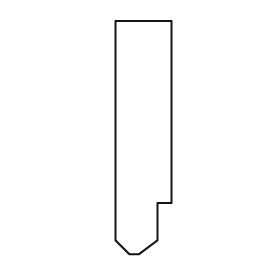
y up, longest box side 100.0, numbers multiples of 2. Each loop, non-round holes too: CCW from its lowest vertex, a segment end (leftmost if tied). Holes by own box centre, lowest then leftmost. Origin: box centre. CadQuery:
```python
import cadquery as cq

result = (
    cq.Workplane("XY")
    .moveTo(-6.0, -50.0)
    .lineTo(-2.0, -50.0)
    .lineTo(6.0, -44.0)
    .lineTo(6.0, -28.0)
    .lineTo(12.0, -28.0)
    .lineTo(12.0, 50.0)
    .lineTo(-12.0, 50.0)
    .lineTo(-12.0, -44.0)
    .close()
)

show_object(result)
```